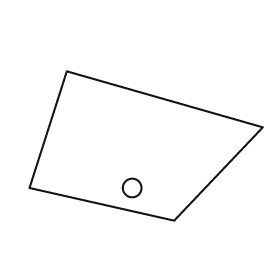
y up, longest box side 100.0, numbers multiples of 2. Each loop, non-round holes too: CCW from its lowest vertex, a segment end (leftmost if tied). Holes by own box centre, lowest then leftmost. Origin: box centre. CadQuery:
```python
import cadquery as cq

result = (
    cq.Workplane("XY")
    .moveTo(12.0, -32.0)
    .lineTo(50.0, 8.0)
    .lineTo(-34.0, 32.0)
    .lineTo(-50.0, -18.0)
    .close()
    .moveTo(-6.0, -18.0)
    .circle(4.0)
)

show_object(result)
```